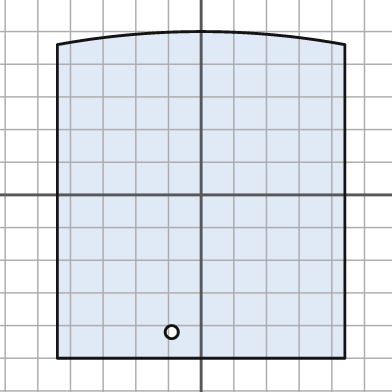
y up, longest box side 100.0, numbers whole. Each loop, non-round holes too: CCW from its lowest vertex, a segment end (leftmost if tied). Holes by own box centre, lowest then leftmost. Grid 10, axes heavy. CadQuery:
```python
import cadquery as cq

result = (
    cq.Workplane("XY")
    .moveTo(-44.0, -50.0)
    .lineTo(44.0, -50.0)
    .lineTo(44.0, 46.0)
    .threePointArc((0.0, 50.0), (-44.0, 46.0))
    .close()
    .moveTo(-9.0, -42.0)
    .circle(2.0)
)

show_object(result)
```